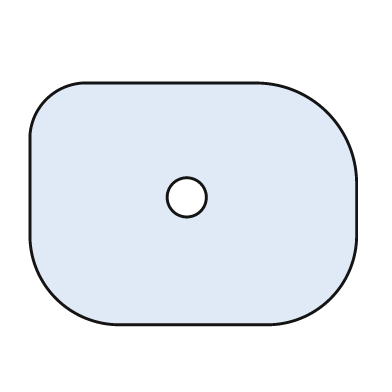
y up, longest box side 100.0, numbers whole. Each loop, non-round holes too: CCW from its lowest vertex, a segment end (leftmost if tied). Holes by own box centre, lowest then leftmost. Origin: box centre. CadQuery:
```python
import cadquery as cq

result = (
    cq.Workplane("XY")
    .moveTo(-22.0, -37.0)
    .lineTo(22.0, -37.0)
    .threePointArc((42.0, -29.0), (50.0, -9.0))
    .lineTo(50.0, 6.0)
    .threePointArc((41.0, 28.0), (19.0, 37.0))
    .lineTo(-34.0, 37.0)
    .threePointArc((-45.0, 32.0), (-50.0, 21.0))
    .lineTo(-50.0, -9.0)
    .threePointArc((-42.0, -29.0), (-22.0, -37.0))
    .close()
    .moveTo(-2.0, 2.0)
    .circle(6.0)
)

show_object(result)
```